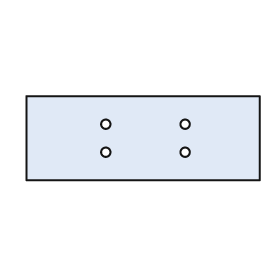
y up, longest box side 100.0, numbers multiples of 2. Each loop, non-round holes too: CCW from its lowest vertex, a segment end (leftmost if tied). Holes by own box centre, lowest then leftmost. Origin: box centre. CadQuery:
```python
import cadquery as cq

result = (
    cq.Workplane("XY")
    .moveTo(-50.0, -18.0)
    .lineTo(50.0, -18.0)
    .lineTo(50.0, 18.0)
    .lineTo(-50.0, 18.0)
    .close()
    .moveTo(-16.0, -6.0)
    .circle(2.0)
    .moveTo(18.0, -6.0)
    .circle(2.0)
    .moveTo(-16.0, 6.0)
    .circle(2.0)
    .moveTo(18.0, 6.0)
    .circle(2.0)
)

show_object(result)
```